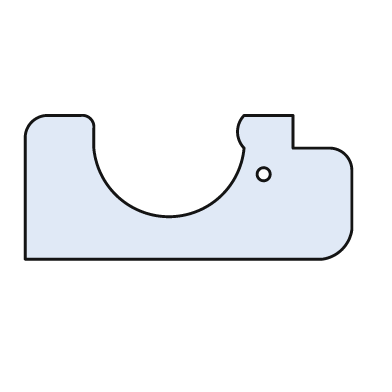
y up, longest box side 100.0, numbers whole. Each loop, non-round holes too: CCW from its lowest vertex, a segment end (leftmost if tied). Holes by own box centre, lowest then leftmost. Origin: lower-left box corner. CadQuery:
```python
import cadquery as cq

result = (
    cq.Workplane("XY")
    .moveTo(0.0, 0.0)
    .lineTo(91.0, 0.0)
    .threePointArc((97.0, 3.0), (100.0, 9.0))
    .lineTo(100.0, 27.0)
    .threePointArc((98.0, 32.0), (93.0, 34.0))
    .lineTo(82.0, 34.0)
    .lineTo(82.0, 44.0)
    .lineTo(67.0, 44.0)
    .threePointArc((65.0, 39.0), (67.0, 34.0))
    .threePointArc((44.0, 13.0), (21.0, 34.0))
    .lineTo(21.0, 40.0)
    .threePointArc((20.0, 43.0), (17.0, 44.0))
    .lineTo(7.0, 44.0)
    .threePointArc((2.0, 42.0), (0.0, 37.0))
    .close()
    .moveTo(73.0, 26.0)
    .circle(2.0)
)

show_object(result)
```